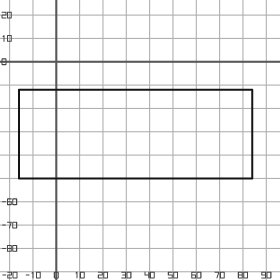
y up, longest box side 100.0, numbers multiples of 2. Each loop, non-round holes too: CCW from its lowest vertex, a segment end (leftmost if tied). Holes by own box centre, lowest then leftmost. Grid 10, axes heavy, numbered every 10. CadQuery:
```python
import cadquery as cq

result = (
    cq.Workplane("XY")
    .moveTo(-16.0, -50.0)
    .lineTo(84.0, -50.0)
    .lineTo(84.0, -12.0)
    .lineTo(-16.0, -12.0)
    .close()
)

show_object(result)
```